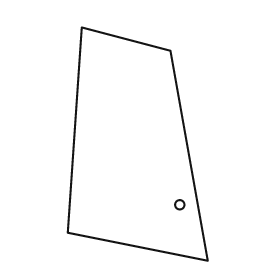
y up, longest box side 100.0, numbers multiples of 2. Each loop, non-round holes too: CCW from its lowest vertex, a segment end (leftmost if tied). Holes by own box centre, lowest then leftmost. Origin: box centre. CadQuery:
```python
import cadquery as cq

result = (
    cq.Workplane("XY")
    .moveTo(30.0, -50.0)
    .lineTo(14.0, 40.0)
    .lineTo(-24.0, 50.0)
    .lineTo(-30.0, -38.0)
    .close()
    .moveTo(18.0, -26.0)
    .circle(2.0)
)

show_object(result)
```